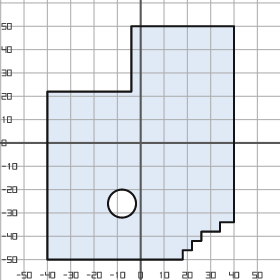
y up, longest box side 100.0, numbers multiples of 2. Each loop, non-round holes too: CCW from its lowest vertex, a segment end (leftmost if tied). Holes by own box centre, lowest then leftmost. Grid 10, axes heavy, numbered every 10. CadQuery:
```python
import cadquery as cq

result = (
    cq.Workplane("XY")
    .moveTo(-40.0, -50.0)
    .lineTo(18.0, -50.0)
    .lineTo(18.0, -46.0)
    .lineTo(22.0, -46.0)
    .lineTo(22.0, -42.0)
    .lineTo(26.0, -42.0)
    .lineTo(26.0, -38.0)
    .lineTo(34.0, -38.0)
    .lineTo(34.0, -34.0)
    .lineTo(40.0, -34.0)
    .lineTo(40.0, 50.0)
    .lineTo(-4.0, 50.0)
    .lineTo(-4.0, 22.0)
    .lineTo(-40.0, 22.0)
    .close()
    .moveTo(-8.0, -26.0)
    .circle(6.0)
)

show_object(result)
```